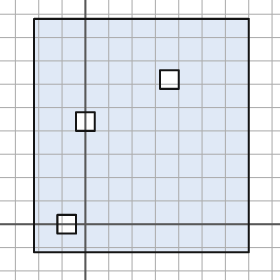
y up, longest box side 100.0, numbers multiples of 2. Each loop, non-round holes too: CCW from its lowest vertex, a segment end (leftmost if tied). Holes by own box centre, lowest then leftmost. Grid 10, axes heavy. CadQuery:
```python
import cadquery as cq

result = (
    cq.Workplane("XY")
    .moveTo(-22.0, -12.0)
    .lineTo(70.0, -12.0)
    .lineTo(70.0, 88.0)
    .lineTo(-22.0, 88.0)
    .close()
    .moveTo(-12.0, -4.0)
    .lineTo(-4.0, -4.0)
    .lineTo(-4.0, 4.0)
    .lineTo(-12.0, 4.0)
    .close()
    .moveTo(-4.0, 40.0)
    .lineTo(4.0, 40.0)
    .lineTo(4.0, 48.0)
    .lineTo(-4.0, 48.0)
    .close()
    .moveTo(32.0, 58.0)
    .lineTo(40.0, 58.0)
    .lineTo(40.0, 66.0)
    .lineTo(32.0, 66.0)
    .close()
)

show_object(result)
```